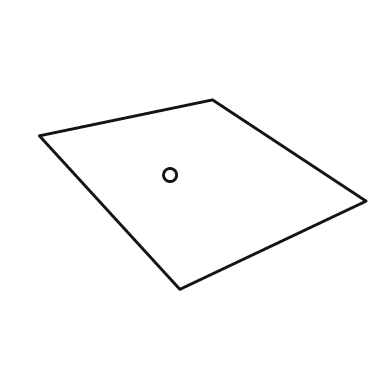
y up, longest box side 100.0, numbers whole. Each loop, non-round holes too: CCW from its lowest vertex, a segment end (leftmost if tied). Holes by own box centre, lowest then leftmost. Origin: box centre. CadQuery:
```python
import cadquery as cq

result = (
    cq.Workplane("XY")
    .moveTo(-7.0, -29.0)
    .lineTo(50.0, -2.0)
    .lineTo(3.0, 29.0)
    .lineTo(-50.0, 18.0)
    .close()
    .moveTo(-10.0, 6.0)
    .circle(2.0)
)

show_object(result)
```